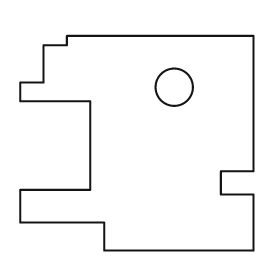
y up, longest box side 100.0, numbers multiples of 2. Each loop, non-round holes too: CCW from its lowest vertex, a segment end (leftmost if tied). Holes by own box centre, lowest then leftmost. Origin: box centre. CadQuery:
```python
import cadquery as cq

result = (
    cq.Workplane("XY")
    .moveTo(-14.0, -46.0)
    .lineTo(50.0, -46.0)
    .lineTo(50.0, -22.0)
    .lineTo(36.0, -22.0)
    .lineTo(36.0, -12.0)
    .lineTo(50.0, -12.0)
    .lineTo(50.0, 46.0)
    .lineTo(-30.0, 46.0)
    .lineTo(-30.0, 42.0)
    .lineTo(-40.0, 42.0)
    .lineTo(-40.0, 26.0)
    .lineTo(-50.0, 26.0)
    .lineTo(-50.0, 18.0)
    .lineTo(-20.0, 18.0)
    .lineTo(-20.0, -20.0)
    .lineTo(-50.0, -20.0)
    .lineTo(-50.0, -34.0)
    .lineTo(-14.0, -34.0)
    .close()
    .moveTo(16.0, 24.0)
    .circle(8.0)
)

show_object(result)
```